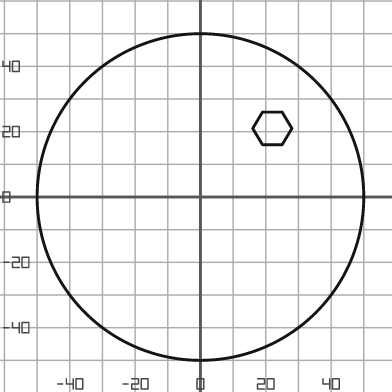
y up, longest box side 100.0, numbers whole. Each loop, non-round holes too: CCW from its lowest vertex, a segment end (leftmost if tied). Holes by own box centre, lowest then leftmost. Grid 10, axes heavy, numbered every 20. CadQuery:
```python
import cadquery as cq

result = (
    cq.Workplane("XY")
    .moveTo(0.0, 0.0)
    .circle(50.0)
    .moveTo(19.0, 16.0)
    .lineTo(25.0, 16.0)
    .lineTo(28.0, 21.0)
    .lineTo(25.0, 26.0)
    .lineTo(19.0, 26.0)
    .lineTo(16.0, 21.0)
    .close()
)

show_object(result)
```